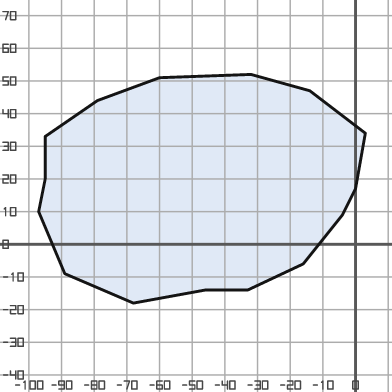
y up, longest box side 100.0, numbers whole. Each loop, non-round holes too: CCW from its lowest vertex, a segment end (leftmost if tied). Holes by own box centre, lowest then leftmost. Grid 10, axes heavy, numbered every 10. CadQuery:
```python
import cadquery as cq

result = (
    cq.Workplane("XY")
    .moveTo(-68.0, -18.0)
    .lineTo(-46.0, -14.0)
    .lineTo(-33.0, -14.0)
    .lineTo(-16.0, -6.0)
    .lineTo(-4.0, 9.0)
    .lineTo(0.0, 17.0)
    .lineTo(3.0, 34.0)
    .lineTo(-14.0, 47.0)
    .lineTo(-32.0, 52.0)
    .lineTo(-60.0, 51.0)
    .lineTo(-79.0, 44.0)
    .lineTo(-95.0, 33.0)
    .lineTo(-95.0, 20.0)
    .lineTo(-97.0, 10.0)
    .lineTo(-89.0, -9.0)
    .close()
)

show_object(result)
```